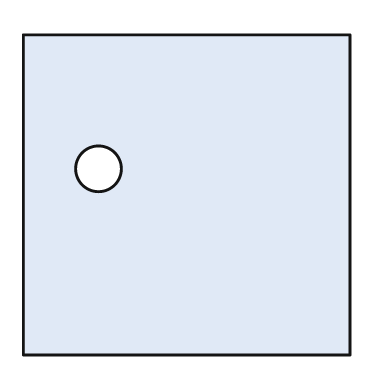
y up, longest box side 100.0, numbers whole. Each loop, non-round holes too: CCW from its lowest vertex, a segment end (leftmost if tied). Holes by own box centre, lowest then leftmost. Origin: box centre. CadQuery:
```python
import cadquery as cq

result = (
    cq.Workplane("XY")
    .moveTo(-50.0, -49.0)
    .lineTo(50.0, -49.0)
    .lineTo(50.0, 49.0)
    .lineTo(-50.0, 49.0)
    .close()
    .moveTo(-27.0, 8.0)
    .circle(7.0)
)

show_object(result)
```